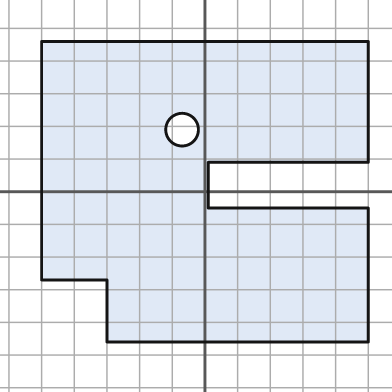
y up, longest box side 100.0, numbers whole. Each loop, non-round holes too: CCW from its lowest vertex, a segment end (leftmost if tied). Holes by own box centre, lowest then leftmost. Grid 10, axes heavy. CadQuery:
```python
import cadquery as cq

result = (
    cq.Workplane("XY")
    .moveTo(-30.0, -46.0)
    .lineTo(50.0, -46.0)
    .lineTo(50.0, -5.0)
    .lineTo(1.0, -5.0)
    .lineTo(1.0, 9.0)
    .lineTo(50.0, 9.0)
    .lineTo(50.0, 46.0)
    .lineTo(-50.0, 46.0)
    .lineTo(-50.0, -27.0)
    .lineTo(-30.0, -27.0)
    .close()
    .moveTo(-7.0, 19.0)
    .circle(5.0)
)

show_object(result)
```